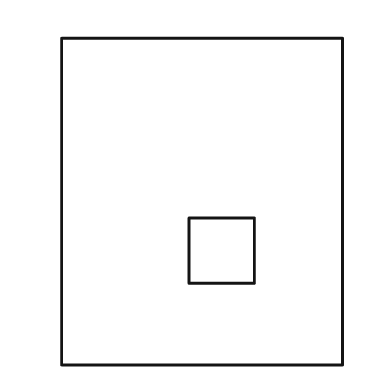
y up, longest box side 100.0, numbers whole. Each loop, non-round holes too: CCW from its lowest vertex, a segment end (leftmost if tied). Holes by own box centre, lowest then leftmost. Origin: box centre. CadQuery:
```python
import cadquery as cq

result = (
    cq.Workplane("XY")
    .moveTo(-43.0, -50.0)
    .lineTo(43.0, -50.0)
    .lineTo(43.0, 50.0)
    .lineTo(-43.0, 50.0)
    .close()
    .moveTo(-4.0, -25.0)
    .lineTo(16.0, -25.0)
    .lineTo(16.0, -5.0)
    .lineTo(-4.0, -5.0)
    .close()
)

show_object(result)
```